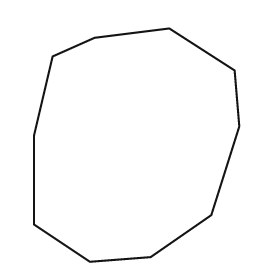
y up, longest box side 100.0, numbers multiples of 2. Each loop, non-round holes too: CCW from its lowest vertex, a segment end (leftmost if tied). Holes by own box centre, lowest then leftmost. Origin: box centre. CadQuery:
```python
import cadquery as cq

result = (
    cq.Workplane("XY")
    .moveTo(-20.0, -50.0)
    .lineTo(6.0, -48.0)
    .lineTo(32.0, -30.0)
    .lineTo(44.0, 8.0)
    .lineTo(42.0, 32.0)
    .lineTo(14.0, 50.0)
    .lineTo(-18.0, 46.0)
    .lineTo(-36.0, 38.0)
    .lineTo(-44.0, 4.0)
    .lineTo(-44.0, -34.0)
    .close()
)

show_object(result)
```